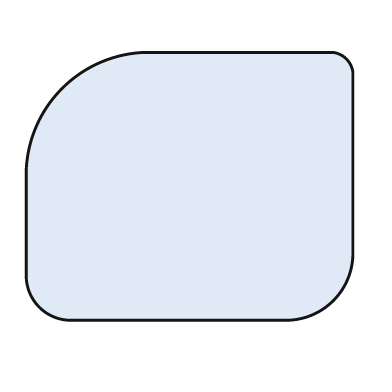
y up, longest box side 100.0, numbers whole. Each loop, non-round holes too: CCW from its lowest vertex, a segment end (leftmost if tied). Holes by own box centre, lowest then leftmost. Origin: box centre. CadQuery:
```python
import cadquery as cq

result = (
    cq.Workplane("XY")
    .moveTo(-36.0, -41.0)
    .lineTo(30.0, -41.0)
    .threePointArc((44.0, -35.0), (50.0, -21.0))
    .lineTo(50.0, 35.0)
    .threePointArc((48.0, 39.0), (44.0, 41.0))
    .lineTo(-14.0, 41.0)
    .threePointArc((-39.0, 30.0), (-50.0, 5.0))
    .lineTo(-50.0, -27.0)
    .threePointArc((-46.0, -37.0), (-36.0, -41.0))
    .close()
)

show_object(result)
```